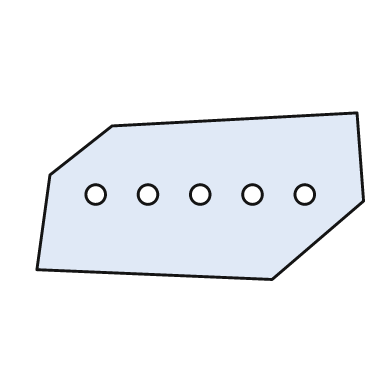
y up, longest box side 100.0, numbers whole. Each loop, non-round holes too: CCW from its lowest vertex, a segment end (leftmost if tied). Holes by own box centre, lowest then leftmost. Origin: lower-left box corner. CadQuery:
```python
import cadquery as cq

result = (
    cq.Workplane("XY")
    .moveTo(72.0, 0.0)
    .lineTo(100.0, 24.0)
    .lineTo(98.0, 51.0)
    .lineTo(23.0, 47.0)
    .lineTo(4.0, 32.0)
    .lineTo(0.0, 3.0)
    .close()
    .moveTo(18.0, 26.0)
    .circle(3.0)
    .moveTo(34.0, 26.0)
    .circle(3.0)
    .moveTo(50.0, 26.0)
    .circle(3.0)
    .moveTo(66.0, 26.0)
    .circle(3.0)
    .moveTo(82.0, 26.0)
    .circle(3.0)
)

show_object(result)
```